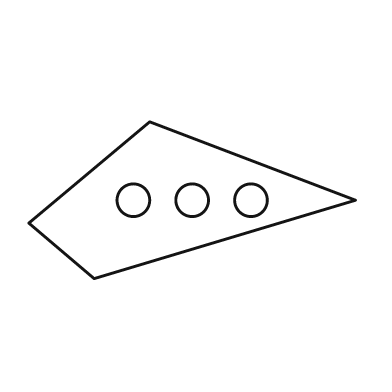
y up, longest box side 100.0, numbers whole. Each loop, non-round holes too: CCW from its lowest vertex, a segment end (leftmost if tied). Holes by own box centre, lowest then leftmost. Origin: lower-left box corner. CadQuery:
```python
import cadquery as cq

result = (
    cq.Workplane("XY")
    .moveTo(20.0, 0.0)
    .lineTo(100.0, 24.0)
    .lineTo(37.0, 48.0)
    .lineTo(0.0, 17.0)
    .close()
    .moveTo(32.0, 24.0)
    .circle(5.0)
    .moveTo(50.0, 24.0)
    .circle(5.0)
    .moveTo(68.0, 24.0)
    .circle(5.0)
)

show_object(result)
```